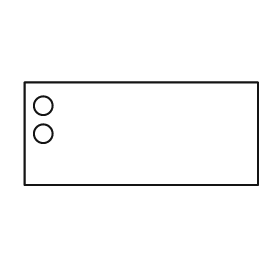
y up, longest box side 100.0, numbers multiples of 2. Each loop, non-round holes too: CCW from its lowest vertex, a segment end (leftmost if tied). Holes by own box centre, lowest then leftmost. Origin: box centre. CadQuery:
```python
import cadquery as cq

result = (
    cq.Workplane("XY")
    .moveTo(-50.0, -22.0)
    .lineTo(50.0, -22.0)
    .lineTo(50.0, 22.0)
    .lineTo(-50.0, 22.0)
    .close()
    .moveTo(-42.0, 0.0)
    .circle(4.0)
    .moveTo(-42.0, 12.0)
    .circle(4.0)
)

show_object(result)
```